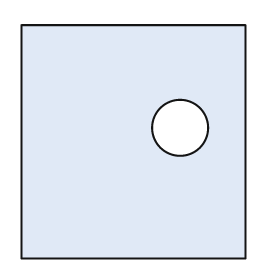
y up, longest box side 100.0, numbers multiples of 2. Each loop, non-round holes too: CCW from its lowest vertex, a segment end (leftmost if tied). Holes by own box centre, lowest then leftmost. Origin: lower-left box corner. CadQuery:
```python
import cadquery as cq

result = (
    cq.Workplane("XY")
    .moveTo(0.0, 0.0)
    .lineTo(96.0, 0.0)
    .lineTo(96.0, 100.0)
    .lineTo(0.0, 100.0)
    .close()
    .moveTo(68.0, 56.0)
    .circle(12.0)
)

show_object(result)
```